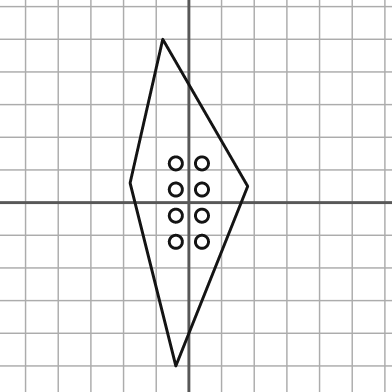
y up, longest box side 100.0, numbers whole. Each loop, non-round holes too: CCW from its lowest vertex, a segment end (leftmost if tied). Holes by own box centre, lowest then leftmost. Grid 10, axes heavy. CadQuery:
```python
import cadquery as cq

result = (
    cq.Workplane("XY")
    .moveTo(-4.0, -50.0)
    .lineTo(18.0, 5.0)
    .lineTo(-8.0, 50.0)
    .lineTo(-18.0, 6.0)
    .close()
    .moveTo(-4.0, -12.0)
    .circle(2.0)
    .moveTo(4.0, -12.0)
    .circle(2.0)
    .moveTo(-4.0, -4.0)
    .circle(2.0)
    .moveTo(4.0, -4.0)
    .circle(2.0)
    .moveTo(-4.0, 4.0)
    .circle(2.0)
    .moveTo(4.0, 4.0)
    .circle(2.0)
    .moveTo(-4.0, 12.0)
    .circle(2.0)
    .moveTo(4.0, 12.0)
    .circle(2.0)
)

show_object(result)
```